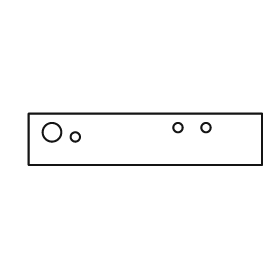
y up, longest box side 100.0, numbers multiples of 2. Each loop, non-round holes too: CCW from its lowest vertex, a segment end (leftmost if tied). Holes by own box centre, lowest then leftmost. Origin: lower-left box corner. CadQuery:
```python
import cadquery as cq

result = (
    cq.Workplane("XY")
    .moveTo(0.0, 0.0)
    .lineTo(100.0, 0.0)
    .lineTo(100.0, 22.0)
    .lineTo(0.0, 22.0)
    .close()
    .moveTo(20.0, 12.0)
    .circle(2.0)
    .moveTo(10.0, 14.0)
    .circle(4.0)
    .moveTo(64.0, 16.0)
    .circle(2.0)
    .moveTo(76.0, 16.0)
    .circle(2.0)
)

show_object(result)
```